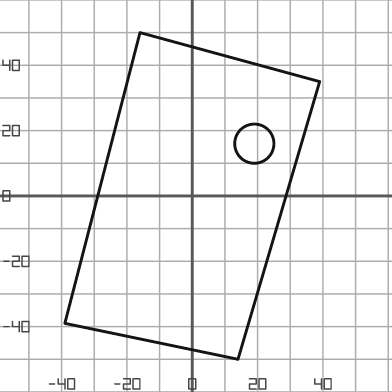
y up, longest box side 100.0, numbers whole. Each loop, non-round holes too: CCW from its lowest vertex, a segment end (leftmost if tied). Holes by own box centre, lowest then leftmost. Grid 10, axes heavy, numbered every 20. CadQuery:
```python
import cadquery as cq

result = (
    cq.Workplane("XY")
    .moveTo(14.0, -50.0)
    .lineTo(39.0, 35.0)
    .lineTo(-16.0, 50.0)
    .lineTo(-39.0, -39.0)
    .close()
    .moveTo(19.0, 16.0)
    .circle(6.0)
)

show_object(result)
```